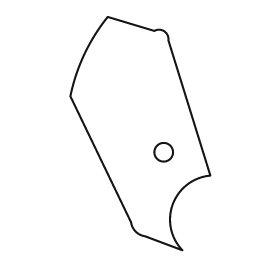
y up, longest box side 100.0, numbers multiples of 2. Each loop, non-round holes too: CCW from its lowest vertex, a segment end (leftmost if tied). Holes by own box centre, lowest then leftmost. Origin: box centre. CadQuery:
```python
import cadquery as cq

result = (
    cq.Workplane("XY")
    .moveTo(18.0, -50.0)
    .threePointArc((14.0, -30.0), (30.0, -18.0))
    .lineTo(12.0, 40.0)
    .threePointArc((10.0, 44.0), (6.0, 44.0))
    .lineTo(-14.0, 50.0)
    .threePointArc((-24.0, 34.0), (-30.0, 16.0))
    .lineTo(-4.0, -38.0)
    .threePointArc((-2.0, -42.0), (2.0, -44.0))
    .close()
    .moveTo(10.0, -8.0)
    .circle(4.0)
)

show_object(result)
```